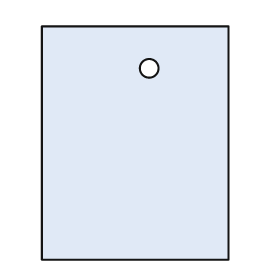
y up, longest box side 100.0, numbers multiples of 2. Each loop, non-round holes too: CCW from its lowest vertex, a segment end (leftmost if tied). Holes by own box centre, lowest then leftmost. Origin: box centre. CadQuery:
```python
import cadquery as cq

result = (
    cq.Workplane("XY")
    .moveTo(-40.0, -50.0)
    .lineTo(40.0, -50.0)
    .lineTo(40.0, 50.0)
    .lineTo(-40.0, 50.0)
    .close()
    .moveTo(6.0, 32.0)
    .circle(4.0)
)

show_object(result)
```